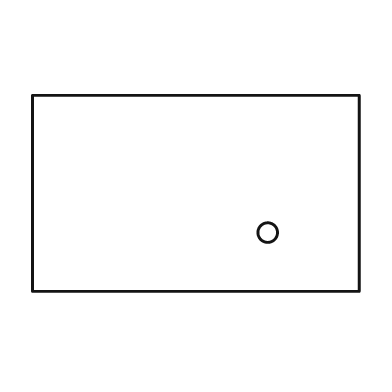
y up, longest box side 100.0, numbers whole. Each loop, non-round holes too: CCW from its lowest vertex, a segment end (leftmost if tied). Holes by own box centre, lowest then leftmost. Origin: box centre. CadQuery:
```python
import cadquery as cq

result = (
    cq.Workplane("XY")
    .moveTo(-50.0, -30.0)
    .lineTo(50.0, -30.0)
    .lineTo(50.0, 30.0)
    .lineTo(-50.0, 30.0)
    .close()
    .moveTo(22.0, -12.0)
    .circle(3.0)
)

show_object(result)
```